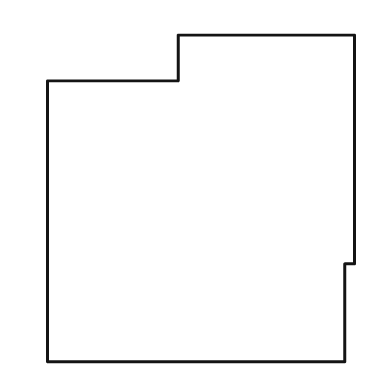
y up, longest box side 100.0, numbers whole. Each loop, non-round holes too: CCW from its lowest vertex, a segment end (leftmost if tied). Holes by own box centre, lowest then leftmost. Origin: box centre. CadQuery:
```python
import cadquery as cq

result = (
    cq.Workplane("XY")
    .moveTo(-47.0, -50.0)
    .lineTo(44.0, -50.0)
    .lineTo(44.0, -20.0)
    .lineTo(47.0, -20.0)
    .lineTo(47.0, 50.0)
    .lineTo(-7.0, 50.0)
    .lineTo(-7.0, 36.0)
    .lineTo(-47.0, 36.0)
    .close()
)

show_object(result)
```